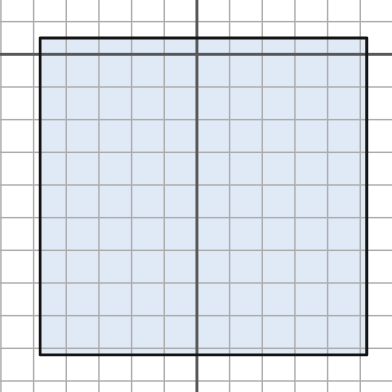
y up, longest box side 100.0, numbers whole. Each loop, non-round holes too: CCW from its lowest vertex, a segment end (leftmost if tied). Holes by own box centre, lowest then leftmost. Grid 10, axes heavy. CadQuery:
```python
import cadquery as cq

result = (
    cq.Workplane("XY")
    .moveTo(-48.0, -92.0)
    .lineTo(52.0, -92.0)
    .lineTo(52.0, 5.0)
    .lineTo(-48.0, 5.0)
    .close()
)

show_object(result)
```